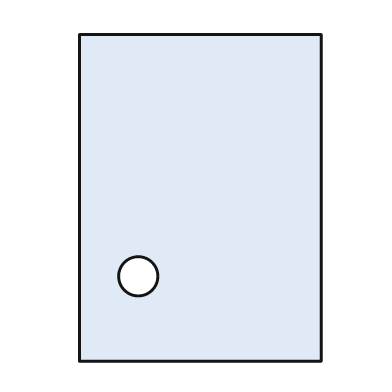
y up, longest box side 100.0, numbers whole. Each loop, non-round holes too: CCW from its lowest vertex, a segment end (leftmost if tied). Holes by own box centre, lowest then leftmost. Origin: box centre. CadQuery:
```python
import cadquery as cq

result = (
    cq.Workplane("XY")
    .moveTo(-37.0, -50.0)
    .lineTo(37.0, -50.0)
    .lineTo(37.0, 50.0)
    .lineTo(-37.0, 50.0)
    .close()
    .moveTo(-19.0, -24.0)
    .circle(6.0)
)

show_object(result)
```